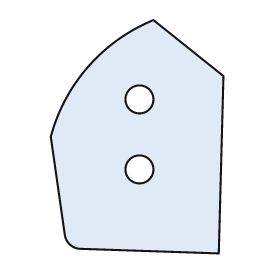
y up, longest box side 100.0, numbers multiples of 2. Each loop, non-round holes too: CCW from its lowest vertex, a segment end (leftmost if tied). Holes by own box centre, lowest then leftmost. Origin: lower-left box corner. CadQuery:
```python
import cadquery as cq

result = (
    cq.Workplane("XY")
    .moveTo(72.0, 0.0)
    .lineTo(74.0, 76.0)
    .lineTo(44.0, 100.0)
    .threePointArc((16.0, 80.0), (0.0, 50.0))
    .lineTo(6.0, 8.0)
    .threePointArc((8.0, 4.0), (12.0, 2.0))
    .close()
    .moveTo(38.0, 36.0)
    .circle(6.0)
    .moveTo(38.0, 66.0)
    .circle(6.0)
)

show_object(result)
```